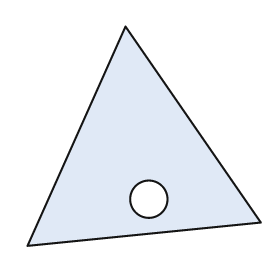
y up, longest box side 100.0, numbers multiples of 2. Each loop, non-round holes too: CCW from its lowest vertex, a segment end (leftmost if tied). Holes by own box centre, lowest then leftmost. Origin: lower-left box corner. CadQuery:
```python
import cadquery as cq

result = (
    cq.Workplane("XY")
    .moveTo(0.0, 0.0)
    .lineTo(100.0, 10.0)
    .lineTo(42.0, 94.0)
    .close()
    .moveTo(52.0, 20.0)
    .circle(8.0)
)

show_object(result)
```